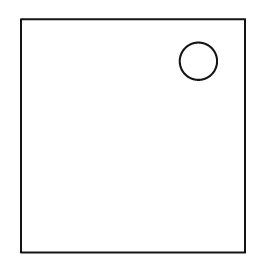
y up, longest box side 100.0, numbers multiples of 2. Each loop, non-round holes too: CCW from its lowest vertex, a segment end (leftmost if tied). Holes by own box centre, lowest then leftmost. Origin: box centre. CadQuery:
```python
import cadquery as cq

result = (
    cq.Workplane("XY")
    .moveTo(-48.0, -50.0)
    .lineTo(48.0, -50.0)
    .lineTo(48.0, 50.0)
    .lineTo(-48.0, 50.0)
    .close()
    .moveTo(28.0, 32.0)
    .circle(8.0)
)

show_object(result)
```